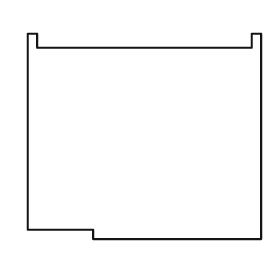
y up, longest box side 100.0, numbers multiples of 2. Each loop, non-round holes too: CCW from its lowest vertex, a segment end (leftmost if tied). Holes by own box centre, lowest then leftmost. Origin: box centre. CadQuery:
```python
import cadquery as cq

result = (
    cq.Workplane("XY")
    .moveTo(-22.0, -44.0)
    .lineTo(50.0, -44.0)
    .lineTo(50.0, 44.0)
    .lineTo(46.0, 44.0)
    .lineTo(46.0, 38.0)
    .lineTo(-46.0, 38.0)
    .lineTo(-46.0, 44.0)
    .lineTo(-50.0, 44.0)
    .lineTo(-50.0, -40.0)
    .lineTo(-22.0, -40.0)
    .close()
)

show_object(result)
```